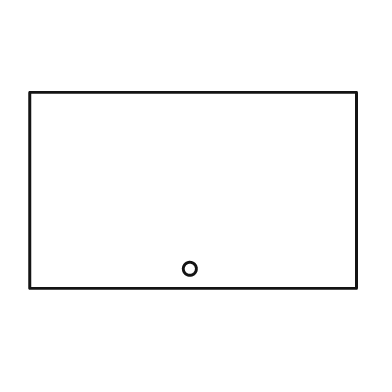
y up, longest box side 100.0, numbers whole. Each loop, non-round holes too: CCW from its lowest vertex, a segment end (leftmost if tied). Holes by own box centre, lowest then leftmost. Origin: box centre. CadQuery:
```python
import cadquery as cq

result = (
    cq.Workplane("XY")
    .moveTo(-50.0, -30.0)
    .lineTo(50.0, -30.0)
    .lineTo(50.0, 30.0)
    .lineTo(-50.0, 30.0)
    .close()
    .moveTo(-1.0, -24.0)
    .circle(2.0)
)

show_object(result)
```